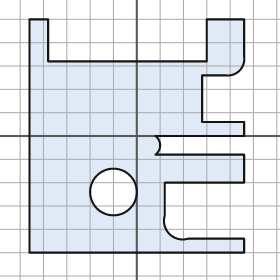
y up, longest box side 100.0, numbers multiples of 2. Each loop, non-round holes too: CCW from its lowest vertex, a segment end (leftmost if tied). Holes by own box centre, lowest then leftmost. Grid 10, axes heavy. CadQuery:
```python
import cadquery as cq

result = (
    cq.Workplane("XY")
    .moveTo(-46.0, -50.0)
    .lineTo(46.0, -50.0)
    .lineTo(46.0, -44.0)
    .lineTo(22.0, -44.0)
    .threePointArc((14.0, -42.0), (12.0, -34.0))
    .lineTo(12.0, -20.0)
    .lineTo(46.0, -20.0)
    .lineTo(46.0, -8.0)
    .lineTo(8.0, -8.0)
    .threePointArc((10.0, -4.0), (8.0, 0.0))
    .lineTo(46.0, 0.0)
    .lineTo(46.0, 6.0)
    .lineTo(28.0, 6.0)
    .lineTo(28.0, 26.0)
    .lineTo(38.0, 26.0)
    .threePointArc((44.0, 28.0), (46.0, 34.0))
    .lineTo(46.0, 50.0)
    .lineTo(30.0, 50.0)
    .lineTo(30.0, 32.0)
    .lineTo(-38.0, 32.0)
    .lineTo(-38.0, 50.0)
    .lineTo(-46.0, 50.0)
    .close()
    .moveTo(-10.0, -24.0)
    .circle(10.0)
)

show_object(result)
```